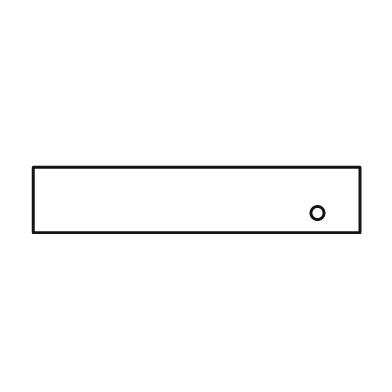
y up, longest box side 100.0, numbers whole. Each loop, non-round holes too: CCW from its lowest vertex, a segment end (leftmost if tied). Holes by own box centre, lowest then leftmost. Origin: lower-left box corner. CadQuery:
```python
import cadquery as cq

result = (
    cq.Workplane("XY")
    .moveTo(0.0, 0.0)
    .lineTo(100.0, 0.0)
    .lineTo(100.0, 20.0)
    .lineTo(0.0, 20.0)
    .close()
    .moveTo(87.0, 6.0)
    .circle(2.0)
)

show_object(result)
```